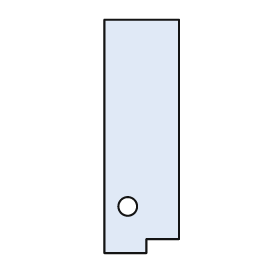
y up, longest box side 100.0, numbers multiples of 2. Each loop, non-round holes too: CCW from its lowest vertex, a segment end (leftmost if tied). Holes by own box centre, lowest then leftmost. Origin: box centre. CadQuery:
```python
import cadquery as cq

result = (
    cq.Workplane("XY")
    .moveTo(-16.0, -50.0)
    .lineTo(2.0, -50.0)
    .lineTo(2.0, -44.0)
    .lineTo(16.0, -44.0)
    .lineTo(16.0, 50.0)
    .lineTo(-16.0, 50.0)
    .close()
    .moveTo(-6.0, -30.0)
    .circle(4.0)
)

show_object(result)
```